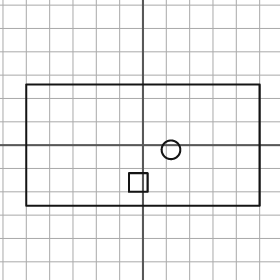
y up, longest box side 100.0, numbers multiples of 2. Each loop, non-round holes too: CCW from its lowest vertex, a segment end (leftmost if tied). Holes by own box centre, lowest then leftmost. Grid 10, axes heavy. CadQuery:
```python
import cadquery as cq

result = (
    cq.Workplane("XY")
    .moveTo(-50.0, -26.0)
    .lineTo(50.0, -26.0)
    .lineTo(50.0, 26.0)
    .lineTo(-50.0, 26.0)
    .close()
    .moveTo(-6.0, -20.0)
    .lineTo(2.0, -20.0)
    .lineTo(2.0, -12.0)
    .lineTo(-6.0, -12.0)
    .close()
    .moveTo(12.0, -2.0)
    .circle(4.0)
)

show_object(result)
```